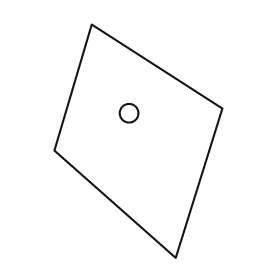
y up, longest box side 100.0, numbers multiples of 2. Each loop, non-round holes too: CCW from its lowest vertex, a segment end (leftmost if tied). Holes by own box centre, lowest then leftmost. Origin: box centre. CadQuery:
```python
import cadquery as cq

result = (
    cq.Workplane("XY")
    .moveTo(16.0, -50.0)
    .lineTo(36.0, 14.0)
    .lineTo(-20.0, 50.0)
    .lineTo(-36.0, -4.0)
    .close()
    .moveTo(-4.0, 12.0)
    .circle(4.0)
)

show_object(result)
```